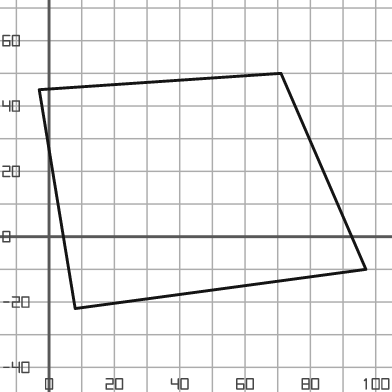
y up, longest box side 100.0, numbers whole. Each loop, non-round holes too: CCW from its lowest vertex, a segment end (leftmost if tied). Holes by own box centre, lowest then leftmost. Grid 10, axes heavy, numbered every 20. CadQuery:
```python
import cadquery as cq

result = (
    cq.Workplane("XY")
    .moveTo(8.0, -22.0)
    .lineTo(97.0, -10.0)
    .lineTo(71.0, 50.0)
    .lineTo(-3.0, 45.0)
    .close()
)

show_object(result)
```